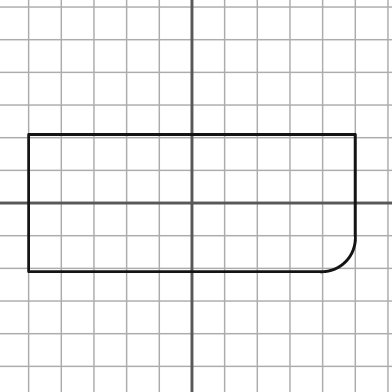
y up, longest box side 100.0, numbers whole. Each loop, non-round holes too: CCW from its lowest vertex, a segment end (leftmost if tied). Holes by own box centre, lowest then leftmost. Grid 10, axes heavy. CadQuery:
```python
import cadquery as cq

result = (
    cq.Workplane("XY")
    .moveTo(-50.0, -21.0)
    .lineTo(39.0, -21.0)
    .threePointArc((47.0, -18.0), (50.0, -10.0))
    .lineTo(50.0, 21.0)
    .lineTo(-50.0, 21.0)
    .close()
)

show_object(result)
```